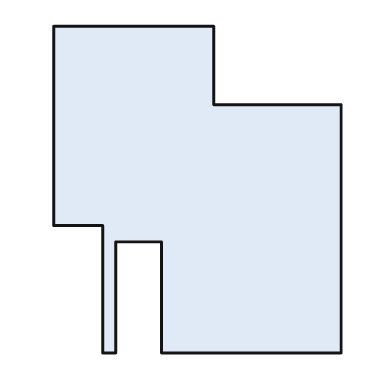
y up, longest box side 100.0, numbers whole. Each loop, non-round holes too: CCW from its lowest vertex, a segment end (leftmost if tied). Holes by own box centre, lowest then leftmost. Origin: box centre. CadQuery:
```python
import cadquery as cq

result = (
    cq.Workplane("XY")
    .moveTo(-29.0, -50.0)
    .lineTo(-25.0, -50.0)
    .lineTo(-25.0, -16.0)
    .lineTo(-11.0, -16.0)
    .lineTo(-11.0, -50.0)
    .lineTo(44.0, -50.0)
    .lineTo(44.0, 26.0)
    .lineTo(5.0, 26.0)
    .lineTo(5.0, 50.0)
    .lineTo(-44.0, 50.0)
    .lineTo(-44.0, -11.0)
    .lineTo(-29.0, -11.0)
    .close()
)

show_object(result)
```